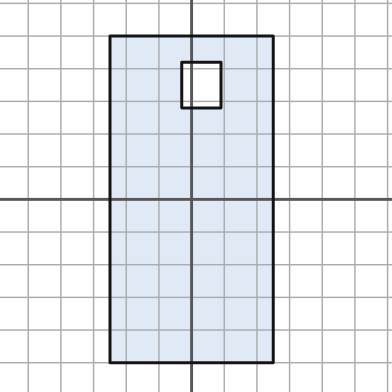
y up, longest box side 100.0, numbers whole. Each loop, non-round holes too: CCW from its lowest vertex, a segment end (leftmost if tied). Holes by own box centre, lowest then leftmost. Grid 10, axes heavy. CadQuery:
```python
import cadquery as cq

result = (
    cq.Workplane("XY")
    .moveTo(-25.0, -50.0)
    .lineTo(25.0, -50.0)
    .lineTo(25.0, 50.0)
    .lineTo(-25.0, 50.0)
    .close()
    .moveTo(-3.0, 28.0)
    .lineTo(9.0, 28.0)
    .lineTo(9.0, 42.0)
    .lineTo(-3.0, 42.0)
    .close()
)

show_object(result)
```